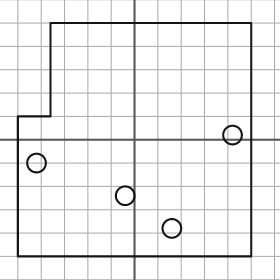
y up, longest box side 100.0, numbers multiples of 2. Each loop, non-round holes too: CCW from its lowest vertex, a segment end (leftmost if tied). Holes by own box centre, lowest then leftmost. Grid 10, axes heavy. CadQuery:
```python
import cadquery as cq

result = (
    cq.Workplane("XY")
    .moveTo(-50.0, -50.0)
    .lineTo(50.0, -50.0)
    .lineTo(50.0, 50.0)
    .lineTo(-36.0, 50.0)
    .lineTo(-36.0, 10.0)
    .lineTo(-50.0, 10.0)
    .close()
    .moveTo(16.0, -38.0)
    .circle(4.0)
    .moveTo(-4.0, -24.0)
    .circle(4.0)
    .moveTo(-42.0, -10.0)
    .circle(4.0)
    .moveTo(42.0, 2.0)
    .circle(4.0)
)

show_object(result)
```